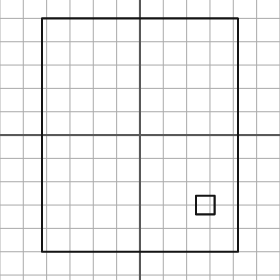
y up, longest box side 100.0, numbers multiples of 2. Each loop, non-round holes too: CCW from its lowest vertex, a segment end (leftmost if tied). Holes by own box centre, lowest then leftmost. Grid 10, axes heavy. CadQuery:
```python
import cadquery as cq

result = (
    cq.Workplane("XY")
    .moveTo(-42.0, -50.0)
    .lineTo(42.0, -50.0)
    .lineTo(42.0, 50.0)
    .lineTo(-42.0, 50.0)
    .close()
    .moveTo(24.0, -34.0)
    .lineTo(32.0, -34.0)
    .lineTo(32.0, -26.0)
    .lineTo(24.0, -26.0)
    .close()
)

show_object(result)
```